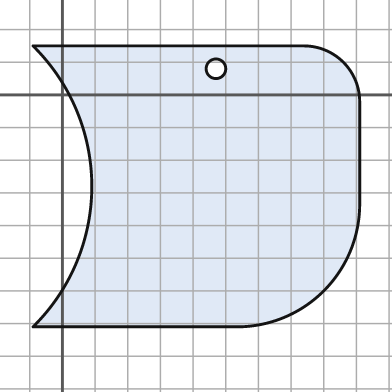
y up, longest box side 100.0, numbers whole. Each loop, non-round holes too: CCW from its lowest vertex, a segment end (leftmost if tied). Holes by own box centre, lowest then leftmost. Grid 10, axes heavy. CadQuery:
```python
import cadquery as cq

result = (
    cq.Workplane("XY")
    .moveTo(-9.0, -71.0)
    .lineTo(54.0, -71.0)
    .threePointArc((80.0, -60.0), (91.0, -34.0))
    .lineTo(91.0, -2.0)
    .threePointArc((86.0, 10.0), (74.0, 15.0))
    .lineTo(-9.0, 15.0)
    .threePointArc((9.0, -28.0), (-9.0, -71.0))
    .close()
    .moveTo(47.0, 8.0)
    .circle(3.0)
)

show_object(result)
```